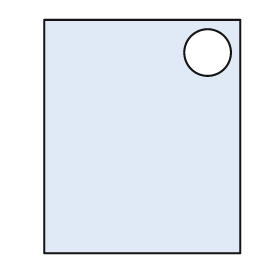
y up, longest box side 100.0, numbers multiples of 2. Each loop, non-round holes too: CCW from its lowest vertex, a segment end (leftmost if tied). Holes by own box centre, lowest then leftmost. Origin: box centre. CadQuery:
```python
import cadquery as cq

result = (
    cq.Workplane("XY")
    .moveTo(-42.0, -50.0)
    .lineTo(42.0, -50.0)
    .lineTo(42.0, 50.0)
    .lineTo(-42.0, 50.0)
    .close()
    .moveTo(28.0, 36.0)
    .circle(10.0)
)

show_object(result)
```